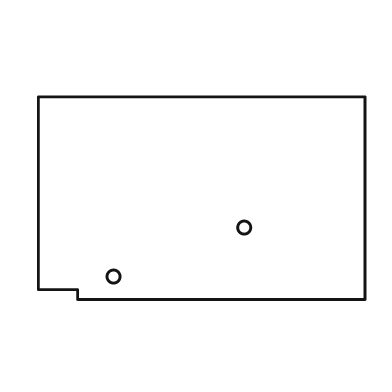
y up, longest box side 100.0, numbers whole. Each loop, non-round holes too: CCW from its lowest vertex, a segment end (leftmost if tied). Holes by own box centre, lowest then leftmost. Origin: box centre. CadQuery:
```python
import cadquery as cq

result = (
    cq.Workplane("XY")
    .moveTo(-38.0, -31.0)
    .lineTo(50.0, -31.0)
    .lineTo(50.0, 31.0)
    .lineTo(-50.0, 31.0)
    .lineTo(-50.0, -28.0)
    .lineTo(-38.0, -28.0)
    .close()
    .moveTo(-27.0, -24.0)
    .circle(2.0)
    .moveTo(13.0, -9.0)
    .circle(2.0)
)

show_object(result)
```